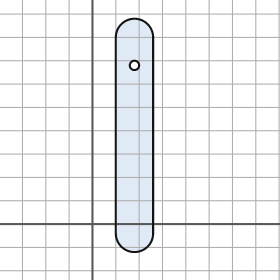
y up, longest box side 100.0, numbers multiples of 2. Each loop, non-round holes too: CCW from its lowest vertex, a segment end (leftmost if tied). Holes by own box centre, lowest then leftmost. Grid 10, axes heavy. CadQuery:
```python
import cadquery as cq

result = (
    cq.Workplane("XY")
    .moveTo(10.0, -4.0)
    .threePointArc((18.0, -12.0), (26.0, -4.0))
    .lineTo(26.0, 80.0)
    .threePointArc((18.0, 88.0), (10.0, 80.0))
    .close()
    .moveTo(18.0, 68.0)
    .circle(2.0)
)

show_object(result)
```